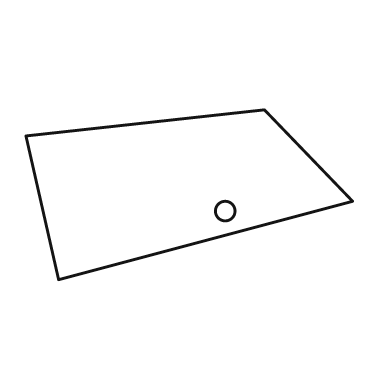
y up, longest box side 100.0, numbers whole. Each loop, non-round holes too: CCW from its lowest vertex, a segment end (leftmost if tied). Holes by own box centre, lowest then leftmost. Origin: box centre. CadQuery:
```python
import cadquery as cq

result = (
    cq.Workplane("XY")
    .moveTo(-40.0, -26.0)
    .lineTo(50.0, -2.0)
    .lineTo(23.0, 26.0)
    .lineTo(-50.0, 18.0)
    .close()
    .moveTo(11.0, -5.0)
    .circle(3.0)
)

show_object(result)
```